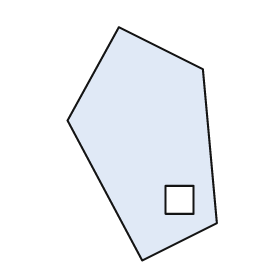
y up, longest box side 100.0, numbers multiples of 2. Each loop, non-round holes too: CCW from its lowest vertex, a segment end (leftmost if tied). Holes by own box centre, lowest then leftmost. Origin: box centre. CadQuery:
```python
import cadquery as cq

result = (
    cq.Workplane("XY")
    .moveTo(0.0, -50.0)
    .lineTo(32.0, -34.0)
    .lineTo(26.0, 32.0)
    .lineTo(-10.0, 50.0)
    .lineTo(-32.0, 10.0)
    .close()
    .moveTo(10.0, -30.0)
    .lineTo(22.0, -30.0)
    .lineTo(22.0, -18.0)
    .lineTo(10.0, -18.0)
    .close()
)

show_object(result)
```